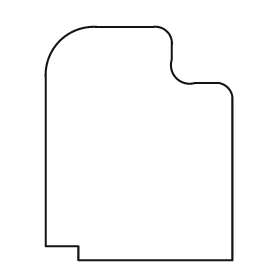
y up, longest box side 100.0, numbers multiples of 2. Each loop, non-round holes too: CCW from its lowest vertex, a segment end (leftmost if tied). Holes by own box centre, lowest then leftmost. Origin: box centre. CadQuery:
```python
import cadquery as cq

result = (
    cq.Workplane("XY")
    .moveTo(-26.0, -50.0)
    .lineTo(40.0, -50.0)
    .lineTo(40.0, 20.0)
    .threePointArc((38.0, 24.0), (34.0, 26.0))
    .lineTo(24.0, 26.0)
    .threePointArc((16.0, 28.0), (14.0, 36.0))
    .lineTo(14.0, 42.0)
    .threePointArc((12.0, 48.0), (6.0, 50.0))
    .lineTo(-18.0, 50.0)
    .threePointArc((-34.0, 44.0), (-40.0, 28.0))
    .lineTo(-40.0, -44.0)
    .lineTo(-26.0, -44.0)
    .close()
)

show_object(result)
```